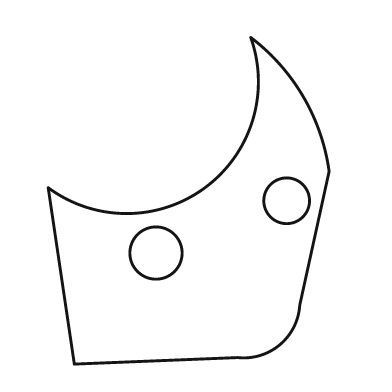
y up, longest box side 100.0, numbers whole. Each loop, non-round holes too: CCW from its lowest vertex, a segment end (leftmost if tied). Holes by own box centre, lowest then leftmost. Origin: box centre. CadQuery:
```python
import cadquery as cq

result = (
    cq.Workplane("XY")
    .moveTo(-35.0, -50.0)
    .lineTo(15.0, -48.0)
    .threePointArc((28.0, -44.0), (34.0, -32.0))
    .lineTo(43.0, 9.0)
    .threePointArc((35.0, 32.0), (19.0, 50.0))
    .threePointArc((5.0, 4.0), (-43.0, 4.0))
    .close()
    .moveTo(-10.0, -16.0)
    .circle(8.0)
    .moveTo(30.0, 0.0)
    .circle(7.0)
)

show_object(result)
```